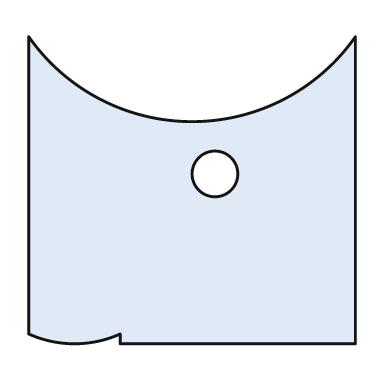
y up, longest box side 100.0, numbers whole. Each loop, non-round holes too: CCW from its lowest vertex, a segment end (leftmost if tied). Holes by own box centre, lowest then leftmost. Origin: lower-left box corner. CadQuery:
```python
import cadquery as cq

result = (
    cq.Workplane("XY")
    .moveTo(28.0, 0.0)
    .lineTo(100.0, 0.0)
    .lineTo(100.0, 94.0)
    .threePointArc((50.0, 68.0), (0.0, 94.0))
    .lineTo(0.0, 3.0)
    .threePointArc((14.0, 0.0), (28.0, 3.0))
    .close()
    .moveTo(57.0, 52.0)
    .circle(7.0)
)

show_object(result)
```